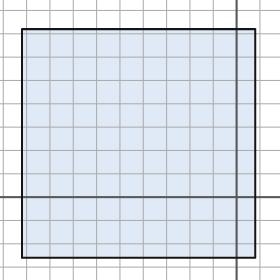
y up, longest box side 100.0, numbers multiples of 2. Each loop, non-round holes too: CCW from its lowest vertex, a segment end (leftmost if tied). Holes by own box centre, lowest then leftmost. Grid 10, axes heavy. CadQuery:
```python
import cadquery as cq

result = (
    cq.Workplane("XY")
    .moveTo(-92.0, -26.0)
    .lineTo(8.0, -26.0)
    .lineTo(8.0, 72.0)
    .lineTo(-92.0, 72.0)
    .close()
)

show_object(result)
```